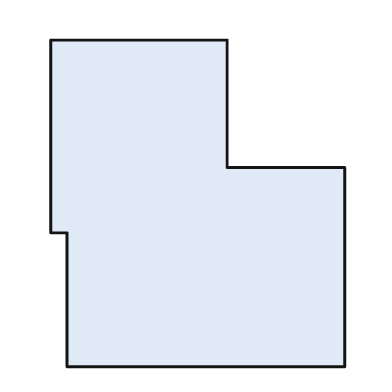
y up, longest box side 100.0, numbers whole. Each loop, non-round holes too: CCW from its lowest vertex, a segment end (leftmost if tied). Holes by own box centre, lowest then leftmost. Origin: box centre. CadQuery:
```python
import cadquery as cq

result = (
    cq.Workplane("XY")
    .moveTo(-40.0, -50.0)
    .lineTo(45.0, -50.0)
    .lineTo(45.0, 11.0)
    .lineTo(9.0, 11.0)
    .lineTo(9.0, 50.0)
    .lineTo(-45.0, 50.0)
    .lineTo(-45.0, -9.0)
    .lineTo(-40.0, -9.0)
    .close()
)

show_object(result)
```